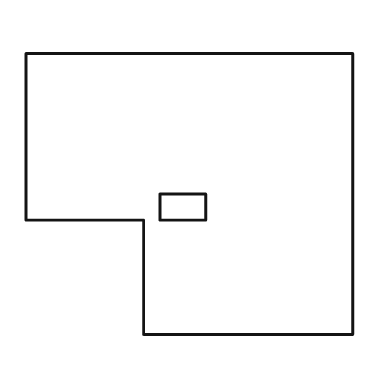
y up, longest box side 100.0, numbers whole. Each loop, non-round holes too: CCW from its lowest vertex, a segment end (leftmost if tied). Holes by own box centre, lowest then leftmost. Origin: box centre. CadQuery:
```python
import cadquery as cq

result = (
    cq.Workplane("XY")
    .moveTo(-14.0, -43.0)
    .lineTo(50.0, -43.0)
    .lineTo(50.0, 43.0)
    .lineTo(-50.0, 43.0)
    .lineTo(-50.0, -8.0)
    .lineTo(-14.0, -8.0)
    .close()
    .moveTo(-9.0, -8.0)
    .lineTo(5.0, -8.0)
    .lineTo(5.0, 0.0)
    .lineTo(-9.0, 0.0)
    .close()
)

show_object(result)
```